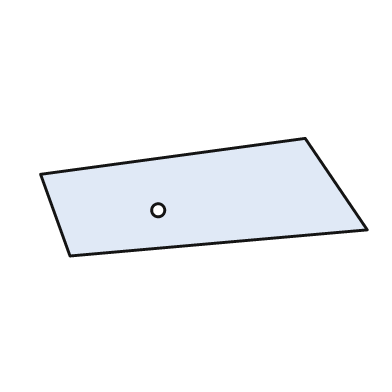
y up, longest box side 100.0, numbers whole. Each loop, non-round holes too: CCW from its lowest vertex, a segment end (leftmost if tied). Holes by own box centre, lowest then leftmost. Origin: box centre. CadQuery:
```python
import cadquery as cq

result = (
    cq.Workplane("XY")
    .moveTo(-41.0, -18.0)
    .lineTo(50.0, -10.0)
    .lineTo(31.0, 18.0)
    .lineTo(-50.0, 7.0)
    .close()
    .moveTo(-14.0, -4.0)
    .circle(2.0)
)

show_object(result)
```